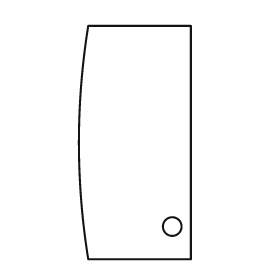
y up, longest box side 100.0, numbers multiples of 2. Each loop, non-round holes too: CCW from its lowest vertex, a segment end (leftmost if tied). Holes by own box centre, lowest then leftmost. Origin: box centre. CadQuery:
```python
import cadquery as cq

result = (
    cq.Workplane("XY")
    .moveTo(-20.0, -50.0)
    .lineTo(24.0, -50.0)
    .lineTo(24.0, 50.0)
    .lineTo(-20.0, 50.0)
    .threePointArc((-24.0, 0.0), (-20.0, -50.0))
    .close()
    .moveTo(16.0, -36.0)
    .circle(4.0)
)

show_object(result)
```